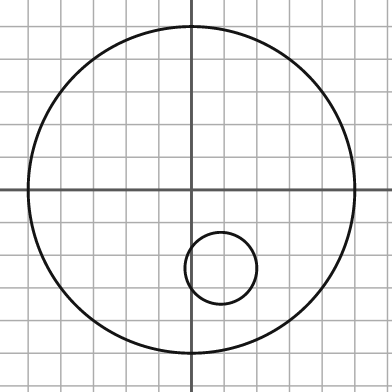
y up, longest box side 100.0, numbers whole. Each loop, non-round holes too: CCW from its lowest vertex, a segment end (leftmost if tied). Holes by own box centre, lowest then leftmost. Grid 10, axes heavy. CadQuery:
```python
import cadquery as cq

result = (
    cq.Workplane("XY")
    .moveTo(0.0, 0.0)
    .circle(50.0)
    .moveTo(9.0, -24.0)
    .circle(11.0)
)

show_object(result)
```